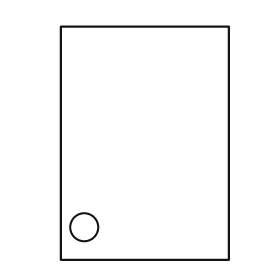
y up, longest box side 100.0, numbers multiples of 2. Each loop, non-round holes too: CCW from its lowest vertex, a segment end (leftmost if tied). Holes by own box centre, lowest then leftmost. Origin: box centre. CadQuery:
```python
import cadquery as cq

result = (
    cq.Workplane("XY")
    .moveTo(-36.0, -50.0)
    .lineTo(36.0, -50.0)
    .lineTo(36.0, 50.0)
    .lineTo(-36.0, 50.0)
    .close()
    .moveTo(-26.0, -36.0)
    .circle(6.0)
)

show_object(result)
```